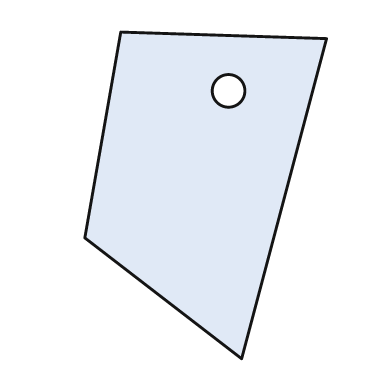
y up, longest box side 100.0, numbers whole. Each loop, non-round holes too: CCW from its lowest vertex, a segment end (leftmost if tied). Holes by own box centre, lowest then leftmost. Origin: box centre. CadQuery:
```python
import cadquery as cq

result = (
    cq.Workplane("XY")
    .moveTo(11.0, -50.0)
    .lineTo(37.0, 48.0)
    .lineTo(-26.0, 50.0)
    .lineTo(-37.0, -13.0)
    .close()
    .moveTo(7.0, 32.0)
    .circle(5.0)
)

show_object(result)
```